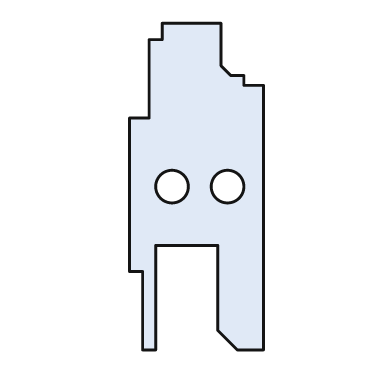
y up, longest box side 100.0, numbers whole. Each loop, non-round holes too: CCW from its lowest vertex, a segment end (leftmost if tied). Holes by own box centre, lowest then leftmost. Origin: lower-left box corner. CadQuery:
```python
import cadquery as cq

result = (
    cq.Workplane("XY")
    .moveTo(4.0, 0.0)
    .lineTo(8.0, 0.0)
    .lineTo(8.0, 32.0)
    .lineTo(27.0, 32.0)
    .lineTo(27.0, 6.0)
    .lineTo(33.0, 0.0)
    .lineTo(41.0, 0.0)
    .lineTo(41.0, 81.0)
    .lineTo(35.0, 81.0)
    .lineTo(35.0, 84.0)
    .lineTo(31.0, 84.0)
    .lineTo(28.0, 87.0)
    .lineTo(28.0, 100.0)
    .lineTo(10.0, 100.0)
    .lineTo(10.0, 95.0)
    .lineTo(6.0, 95.0)
    .lineTo(6.0, 71.0)
    .lineTo(0.0, 71.0)
    .lineTo(0.0, 24.0)
    .lineTo(4.0, 24.0)
    .close()
    .moveTo(13.0, 50.0)
    .circle(5.0)
    .moveTo(30.0, 50.0)
    .circle(5.0)
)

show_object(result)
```